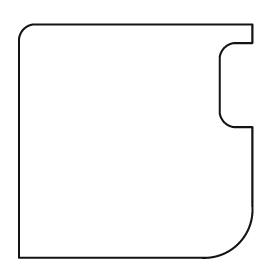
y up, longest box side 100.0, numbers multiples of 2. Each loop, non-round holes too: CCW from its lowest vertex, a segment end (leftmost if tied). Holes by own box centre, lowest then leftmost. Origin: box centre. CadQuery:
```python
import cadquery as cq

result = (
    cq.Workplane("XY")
    .moveTo(-50.0, -50.0)
    .lineTo(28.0, -50.0)
    .threePointArc((44.0, -44.0), (50.0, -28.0))
    .lineTo(50.0, 6.0)
    .lineTo(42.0, 6.0)
    .threePointArc((38.0, 8.0), (36.0, 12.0))
    .lineTo(36.0, 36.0)
    .threePointArc((38.0, 40.0), (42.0, 42.0))
    .lineTo(50.0, 42.0)
    .lineTo(50.0, 50.0)
    .lineTo(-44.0, 50.0)
    .threePointArc((-48.0, 48.0), (-50.0, 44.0))
    .close()
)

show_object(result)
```